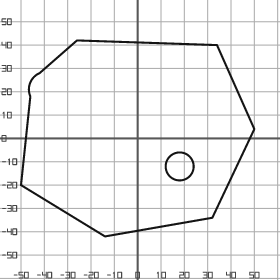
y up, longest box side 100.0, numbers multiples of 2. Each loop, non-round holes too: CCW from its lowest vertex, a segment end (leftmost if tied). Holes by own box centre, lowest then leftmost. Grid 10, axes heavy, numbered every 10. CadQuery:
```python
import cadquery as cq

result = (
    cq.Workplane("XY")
    .moveTo(-14.0, -42.0)
    .lineTo(32.0, -34.0)
    .lineTo(50.0, 4.0)
    .lineTo(34.0, 40.0)
    .lineTo(-26.0, 42.0)
    .lineTo(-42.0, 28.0)
    .threePointArc((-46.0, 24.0), (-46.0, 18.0))
    .lineTo(-50.0, -20.0)
    .close()
    .moveTo(18.0, -12.0)
    .circle(6.0)
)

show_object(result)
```